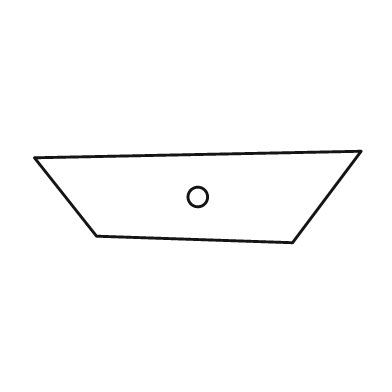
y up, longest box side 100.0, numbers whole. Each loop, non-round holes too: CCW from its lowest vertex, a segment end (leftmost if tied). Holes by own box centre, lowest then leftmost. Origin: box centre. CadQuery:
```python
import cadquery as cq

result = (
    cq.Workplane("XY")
    .moveTo(29.0, -14.0)
    .lineTo(50.0, 14.0)
    .lineTo(-50.0, 12.0)
    .lineTo(-31.0, -12.0)
    .close()
    .moveTo(0.0, 0.0)
    .circle(3.0)
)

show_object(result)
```